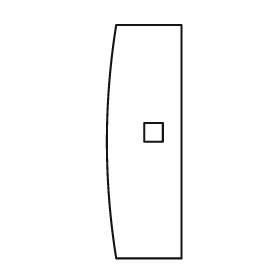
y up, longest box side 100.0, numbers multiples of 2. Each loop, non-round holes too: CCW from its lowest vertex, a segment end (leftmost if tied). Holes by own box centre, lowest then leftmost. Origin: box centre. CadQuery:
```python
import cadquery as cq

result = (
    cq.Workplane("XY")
    .moveTo(-12.0, -50.0)
    .lineTo(16.0, -50.0)
    .lineTo(16.0, 50.0)
    .lineTo(-12.0, 50.0)
    .threePointArc((-16.0, 0.0), (-12.0, -50.0))
    .close()
    .moveTo(0.0, 0.0)
    .lineTo(8.0, 0.0)
    .lineTo(8.0, 8.0)
    .lineTo(0.0, 8.0)
    .close()
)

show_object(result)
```